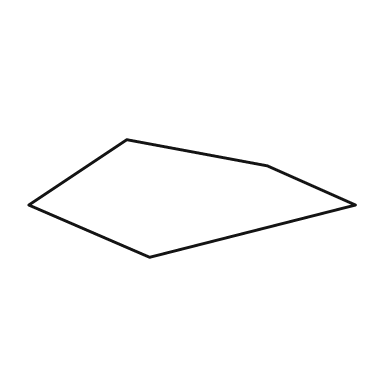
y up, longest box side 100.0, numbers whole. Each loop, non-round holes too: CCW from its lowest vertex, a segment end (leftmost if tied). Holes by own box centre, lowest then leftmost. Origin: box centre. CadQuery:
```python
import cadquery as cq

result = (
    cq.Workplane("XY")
    .moveTo(-13.0, -18.0)
    .lineTo(50.0, -2.0)
    .lineTo(23.0, 10.0)
    .lineTo(-20.0, 18.0)
    .lineTo(-50.0, -2.0)
    .close()
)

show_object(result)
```